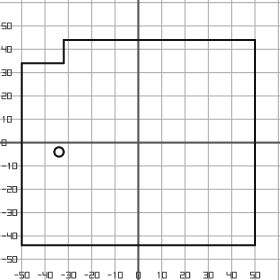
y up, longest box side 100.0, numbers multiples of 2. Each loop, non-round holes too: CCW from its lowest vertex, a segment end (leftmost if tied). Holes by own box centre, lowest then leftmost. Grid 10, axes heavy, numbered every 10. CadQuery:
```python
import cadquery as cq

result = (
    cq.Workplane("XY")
    .moveTo(-50.0, -44.0)
    .lineTo(50.0, -44.0)
    .lineTo(50.0, 44.0)
    .lineTo(-32.0, 44.0)
    .lineTo(-32.0, 34.0)
    .lineTo(-50.0, 34.0)
    .close()
    .moveTo(-34.0, -4.0)
    .circle(2.0)
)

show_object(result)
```